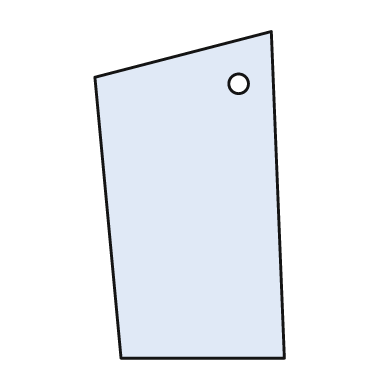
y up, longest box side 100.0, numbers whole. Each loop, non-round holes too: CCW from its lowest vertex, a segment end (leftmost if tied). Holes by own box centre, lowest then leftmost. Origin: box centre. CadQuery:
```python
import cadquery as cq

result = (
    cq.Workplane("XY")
    .moveTo(-21.0, -50.0)
    .lineTo(29.0, -50.0)
    .lineTo(25.0, 50.0)
    .lineTo(-29.0, 36.0)
    .close()
    .moveTo(15.0, 34.0)
    .circle(3.0)
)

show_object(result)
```